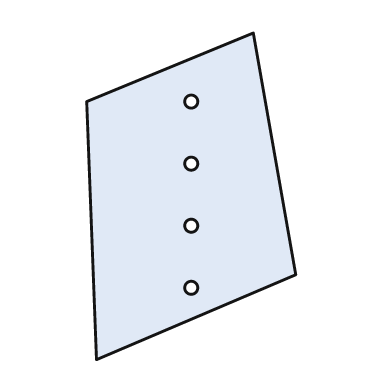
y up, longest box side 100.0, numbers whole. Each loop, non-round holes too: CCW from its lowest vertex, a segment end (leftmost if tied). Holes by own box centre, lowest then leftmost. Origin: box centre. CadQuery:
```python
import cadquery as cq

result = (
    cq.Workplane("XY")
    .moveTo(-29.0, -50.0)
    .lineTo(32.0, -24.0)
    .lineTo(19.0, 50.0)
    .lineTo(-32.0, 29.0)
    .close()
    .moveTo(0.0, -28.0)
    .circle(2.0)
    .moveTo(0.0, -9.0)
    .circle(2.0)
    .moveTo(0.0, 10.0)
    .circle(2.0)
    .moveTo(0.0, 29.0)
    .circle(2.0)
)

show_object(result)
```